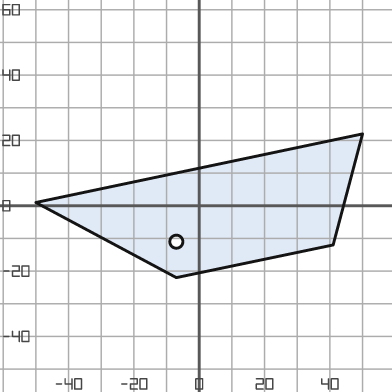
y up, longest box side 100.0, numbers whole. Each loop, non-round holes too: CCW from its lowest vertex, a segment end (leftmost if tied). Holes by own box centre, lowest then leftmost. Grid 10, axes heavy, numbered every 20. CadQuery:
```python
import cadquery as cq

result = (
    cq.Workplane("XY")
    .moveTo(-7.0, -22.0)
    .lineTo(41.0, -12.0)
    .lineTo(50.0, 22.0)
    .lineTo(-50.0, 1.0)
    .close()
    .moveTo(-7.0, -11.0)
    .circle(2.0)
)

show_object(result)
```